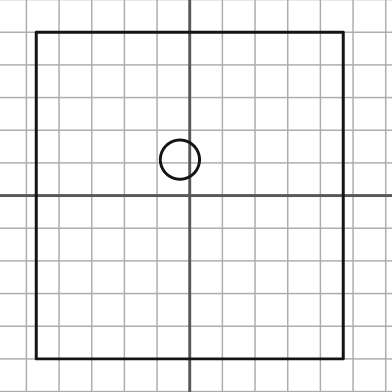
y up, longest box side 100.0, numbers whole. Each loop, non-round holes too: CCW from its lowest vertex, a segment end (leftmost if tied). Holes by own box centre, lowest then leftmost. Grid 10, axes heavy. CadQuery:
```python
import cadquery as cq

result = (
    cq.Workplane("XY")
    .moveTo(-47.0, -50.0)
    .lineTo(47.0, -50.0)
    .lineTo(47.0, 50.0)
    .lineTo(-47.0, 50.0)
    .close()
    .moveTo(-3.0, 11.0)
    .circle(6.0)
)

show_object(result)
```